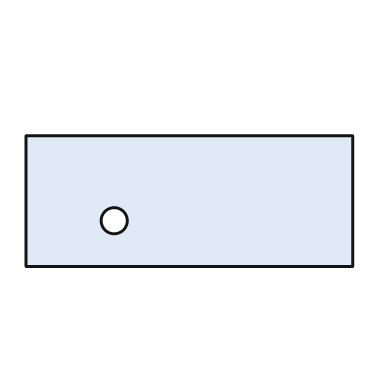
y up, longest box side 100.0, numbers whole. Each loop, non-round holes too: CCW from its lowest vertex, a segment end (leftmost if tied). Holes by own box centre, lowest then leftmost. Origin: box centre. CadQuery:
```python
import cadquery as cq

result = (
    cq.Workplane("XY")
    .moveTo(-50.0, -20.0)
    .lineTo(50.0, -20.0)
    .lineTo(50.0, 20.0)
    .lineTo(-50.0, 20.0)
    .close()
    .moveTo(-23.0, -6.0)
    .circle(4.0)
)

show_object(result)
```